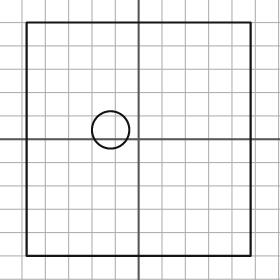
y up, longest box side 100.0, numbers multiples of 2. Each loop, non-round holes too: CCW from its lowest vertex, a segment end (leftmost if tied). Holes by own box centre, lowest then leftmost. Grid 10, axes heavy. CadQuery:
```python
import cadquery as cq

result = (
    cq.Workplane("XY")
    .moveTo(-48.0, -50.0)
    .lineTo(48.0, -50.0)
    .lineTo(48.0, 50.0)
    .lineTo(-48.0, 50.0)
    .close()
    .moveTo(-12.0, 4.0)
    .circle(8.0)
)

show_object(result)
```